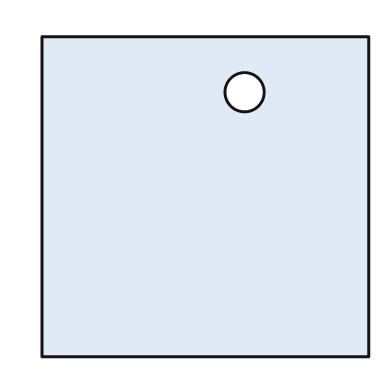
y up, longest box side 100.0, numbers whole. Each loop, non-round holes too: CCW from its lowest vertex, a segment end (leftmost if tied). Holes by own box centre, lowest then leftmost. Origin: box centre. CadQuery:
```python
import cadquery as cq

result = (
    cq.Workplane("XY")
    .moveTo(-50.0, -49.0)
    .lineTo(50.0, -49.0)
    .lineTo(50.0, 49.0)
    .lineTo(-50.0, 49.0)
    .close()
    .moveTo(12.0, 32.0)
    .circle(6.0)
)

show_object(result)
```